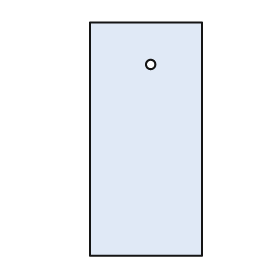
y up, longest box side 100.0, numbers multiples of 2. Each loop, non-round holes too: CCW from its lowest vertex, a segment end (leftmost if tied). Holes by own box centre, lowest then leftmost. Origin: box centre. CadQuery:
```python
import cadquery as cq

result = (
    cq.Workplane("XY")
    .moveTo(-24.0, -50.0)
    .lineTo(24.0, -50.0)
    .lineTo(24.0, 50.0)
    .lineTo(-24.0, 50.0)
    .close()
    .moveTo(2.0, 32.0)
    .circle(2.0)
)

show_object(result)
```